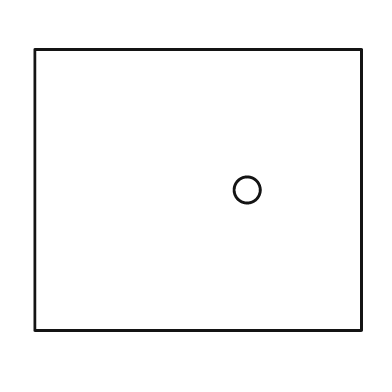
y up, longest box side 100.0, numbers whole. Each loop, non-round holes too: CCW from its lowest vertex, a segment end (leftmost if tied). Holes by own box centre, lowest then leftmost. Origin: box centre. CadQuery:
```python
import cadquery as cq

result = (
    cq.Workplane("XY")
    .moveTo(-50.0, -43.0)
    .lineTo(50.0, -43.0)
    .lineTo(50.0, 43.0)
    .lineTo(-50.0, 43.0)
    .close()
    .moveTo(15.0, 0.0)
    .circle(4.0)
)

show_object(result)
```